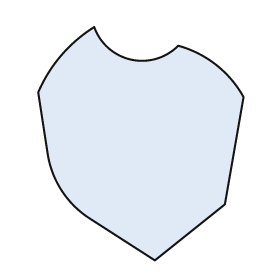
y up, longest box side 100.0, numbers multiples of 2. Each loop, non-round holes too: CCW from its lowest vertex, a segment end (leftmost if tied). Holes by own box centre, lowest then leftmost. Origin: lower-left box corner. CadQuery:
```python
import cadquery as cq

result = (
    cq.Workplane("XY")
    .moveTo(50.0, 0.0)
    .lineTo(80.0, 24.0)
    .lineTo(88.0, 70.0)
    .threePointArc((76.0, 84.0), (60.0, 92.0))
    .threePointArc((40.0, 86.0), (24.0, 100.0))
    .threePointArc((10.0, 88.0), (0.0, 72.0))
    .lineTo(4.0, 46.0)
    .threePointArc((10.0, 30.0), (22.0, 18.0))
    .close()
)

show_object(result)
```